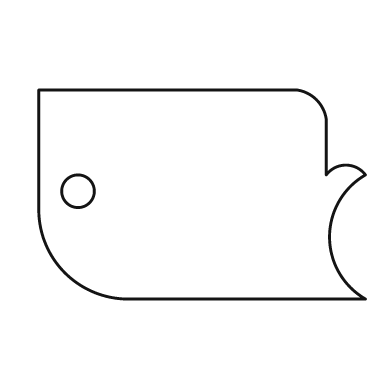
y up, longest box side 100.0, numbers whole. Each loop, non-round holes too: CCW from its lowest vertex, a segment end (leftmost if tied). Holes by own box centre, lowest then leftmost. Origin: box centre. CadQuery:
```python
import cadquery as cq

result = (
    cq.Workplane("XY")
    .moveTo(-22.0, -32.0)
    .lineTo(50.0, -32.0)
    .threePointArc((39.0, -13.0), (50.0, 6.0))
    .threePointArc((44.0, 9.0), (38.0, 6.0))
    .lineTo(38.0, 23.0)
    .threePointArc((35.0, 29.0), (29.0, 32.0))
    .lineTo(-50.0, 32.0)
    .lineTo(-50.0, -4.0)
    .threePointArc((-42.0, -24.0), (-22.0, -32.0))
    .close()
    .moveTo(-38.0, 1.0)
    .circle(5.0)
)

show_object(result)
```